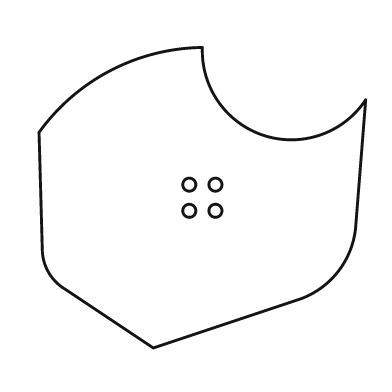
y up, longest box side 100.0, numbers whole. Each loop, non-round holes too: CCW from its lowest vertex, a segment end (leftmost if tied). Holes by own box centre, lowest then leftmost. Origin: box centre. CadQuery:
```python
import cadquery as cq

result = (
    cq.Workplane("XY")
    .moveTo(-15.0, -46.0)
    .lineTo(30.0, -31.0)
    .threePointArc((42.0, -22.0), (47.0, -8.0))
    .lineTo(50.0, 30.0)
    .threePointArc((19.0, 19.0), (0.0, 46.0))
    .threePointArc((-28.0, 39.0), (-50.0, 20.0))
    .lineTo(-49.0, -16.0)
    .threePointArc((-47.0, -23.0), (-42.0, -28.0))
    .close()
    .moveTo(-4.0, -4.0)
    .circle(2.0)
    .moveTo(4.0, -4.0)
    .circle(2.0)
    .moveTo(-4.0, 4.0)
    .circle(2.0)
    .moveTo(4.0, 4.0)
    .circle(2.0)
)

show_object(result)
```